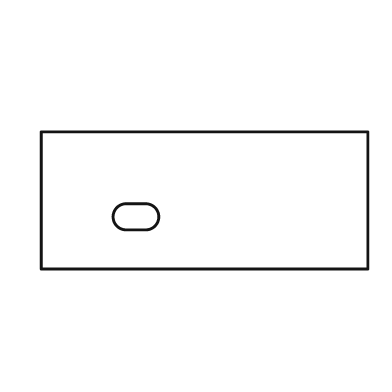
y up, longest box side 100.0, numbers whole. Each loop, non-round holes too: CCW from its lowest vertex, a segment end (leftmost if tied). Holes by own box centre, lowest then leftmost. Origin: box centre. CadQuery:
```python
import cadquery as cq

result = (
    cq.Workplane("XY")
    .moveTo(-50.0, -21.0)
    .lineTo(50.0, -21.0)
    .lineTo(50.0, 21.0)
    .lineTo(-50.0, 21.0)
    .close()
    .moveTo(-24.0, -9.0)
    .lineTo(-18.0, -9.0)
    .threePointArc((-14.0, -5.0), (-18.0, -1.0))
    .lineTo(-24.0, -1.0)
    .threePointArc((-28.0, -5.0), (-24.0, -9.0))
    .close()
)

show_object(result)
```